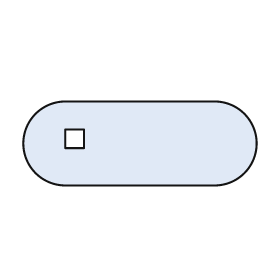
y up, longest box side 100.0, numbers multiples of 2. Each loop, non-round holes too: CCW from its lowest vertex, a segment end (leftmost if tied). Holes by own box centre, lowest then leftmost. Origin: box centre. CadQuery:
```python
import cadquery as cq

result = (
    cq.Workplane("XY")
    .moveTo(-32.0, -18.0)
    .lineTo(32.0, -18.0)
    .threePointArc((50.0, 0.0), (32.0, 18.0))
    .lineTo(-32.0, 18.0)
    .threePointArc((-50.0, 0.0), (-32.0, -18.0))
    .close()
    .moveTo(-32.0, -2.0)
    .lineTo(-24.0, -2.0)
    .lineTo(-24.0, 6.0)
    .lineTo(-32.0, 6.0)
    .close()
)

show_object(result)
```